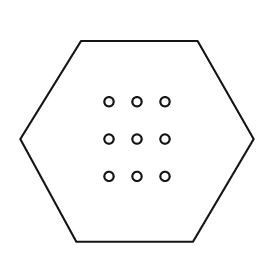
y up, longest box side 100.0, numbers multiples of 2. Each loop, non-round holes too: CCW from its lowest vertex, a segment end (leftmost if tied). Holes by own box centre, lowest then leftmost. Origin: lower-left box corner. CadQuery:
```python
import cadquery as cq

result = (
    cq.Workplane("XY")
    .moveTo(24.0, 0.0)
    .lineTo(74.0, 0.0)
    .lineTo(100.0, 44.0)
    .lineTo(76.0, 86.0)
    .lineTo(26.0, 86.0)
    .lineTo(0.0, 44.0)
    .close()
    .moveTo(38.0, 28.0)
    .circle(2.0)
    .moveTo(50.0, 28.0)
    .circle(2.0)
    .moveTo(62.0, 28.0)
    .circle(2.0)
    .moveTo(38.0, 44.0)
    .circle(2.0)
    .moveTo(50.0, 44.0)
    .circle(2.0)
    .moveTo(62.0, 44.0)
    .circle(2.0)
    .moveTo(38.0, 60.0)
    .circle(2.0)
    .moveTo(50.0, 60.0)
    .circle(2.0)
    .moveTo(62.0, 60.0)
    .circle(2.0)
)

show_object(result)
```